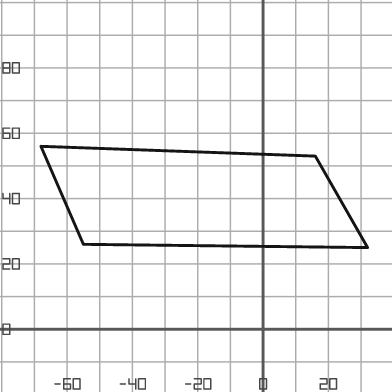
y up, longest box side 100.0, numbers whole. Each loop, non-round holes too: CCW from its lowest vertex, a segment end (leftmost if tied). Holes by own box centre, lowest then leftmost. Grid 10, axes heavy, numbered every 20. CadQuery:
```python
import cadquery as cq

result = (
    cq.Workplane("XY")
    .moveTo(32.0, 25.0)
    .lineTo(16.0, 53.0)
    .lineTo(-68.0, 56.0)
    .lineTo(-55.0, 26.0)
    .close()
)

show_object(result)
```